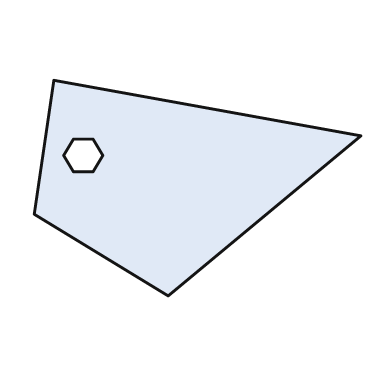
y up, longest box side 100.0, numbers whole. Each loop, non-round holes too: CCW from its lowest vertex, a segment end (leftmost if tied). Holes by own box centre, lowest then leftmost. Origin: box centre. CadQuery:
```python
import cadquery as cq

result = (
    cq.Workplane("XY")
    .moveTo(-9.0, -33.0)
    .lineTo(50.0, 16.0)
    .lineTo(-44.0, 33.0)
    .lineTo(-50.0, -8.0)
    .close()
    .moveTo(-38.0, 5.0)
    .lineTo(-32.0, 5.0)
    .lineTo(-29.0, 10.0)
    .lineTo(-32.0, 15.0)
    .lineTo(-38.0, 15.0)
    .lineTo(-41.0, 10.0)
    .close()
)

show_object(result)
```